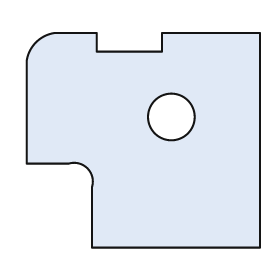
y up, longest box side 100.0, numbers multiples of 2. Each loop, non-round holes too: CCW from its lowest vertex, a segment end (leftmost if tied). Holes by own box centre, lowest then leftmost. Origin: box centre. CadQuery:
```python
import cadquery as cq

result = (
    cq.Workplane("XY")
    .moveTo(-22.0, -46.0)
    .lineTo(50.0, -46.0)
    .lineTo(50.0, 46.0)
    .lineTo(8.0, 46.0)
    .lineTo(8.0, 38.0)
    .lineTo(-20.0, 38.0)
    .lineTo(-20.0, 46.0)
    .lineTo(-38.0, 46.0)
    .threePointArc((-46.0, 42.0), (-50.0, 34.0))
    .lineTo(-50.0, -10.0)
    .lineTo(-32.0, -10.0)
    .threePointArc((-24.0, -12.0), (-22.0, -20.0))
    .close()
    .moveTo(12.0, 10.0)
    .circle(10.0)
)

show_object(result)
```